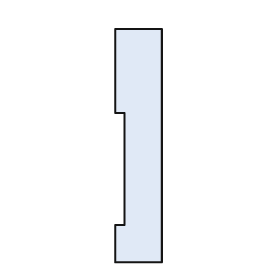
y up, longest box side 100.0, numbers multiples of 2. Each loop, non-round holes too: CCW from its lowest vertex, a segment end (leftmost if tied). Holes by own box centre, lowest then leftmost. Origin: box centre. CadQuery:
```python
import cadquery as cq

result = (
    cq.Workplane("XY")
    .moveTo(-10.0, -50.0)
    .lineTo(10.0, -50.0)
    .lineTo(10.0, 50.0)
    .lineTo(-10.0, 50.0)
    .lineTo(-10.0, 14.0)
    .lineTo(-6.0, 14.0)
    .lineTo(-6.0, -34.0)
    .lineTo(-10.0, -34.0)
    .close()
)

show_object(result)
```